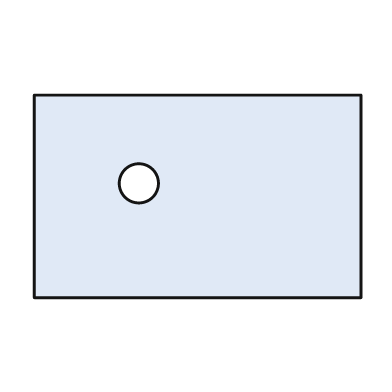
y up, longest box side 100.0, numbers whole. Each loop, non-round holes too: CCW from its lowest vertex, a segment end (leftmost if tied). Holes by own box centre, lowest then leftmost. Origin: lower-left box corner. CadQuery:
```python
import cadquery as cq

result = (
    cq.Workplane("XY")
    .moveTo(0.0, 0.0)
    .lineTo(100.0, 0.0)
    .lineTo(100.0, 62.0)
    .lineTo(0.0, 62.0)
    .close()
    .moveTo(32.0, 35.0)
    .circle(6.0)
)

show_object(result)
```